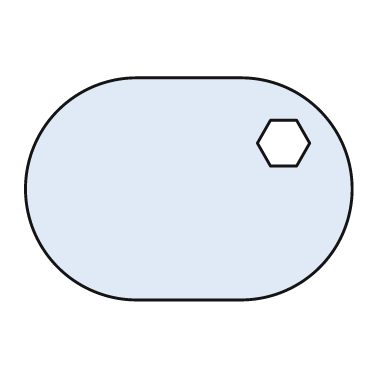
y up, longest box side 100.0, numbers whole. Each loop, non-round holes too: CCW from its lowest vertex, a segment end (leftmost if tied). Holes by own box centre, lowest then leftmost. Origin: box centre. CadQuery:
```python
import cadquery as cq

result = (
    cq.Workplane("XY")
    .moveTo(-16.0, -34.0)
    .lineTo(16.0, -34.0)
    .threePointArc((50.0, 0.0), (16.0, 34.0))
    .lineTo(-16.0, 34.0)
    .threePointArc((-50.0, 0.0), (-16.0, -34.0))
    .close()
    .moveTo(25.0, 7.0)
    .lineTo(33.0, 7.0)
    .lineTo(37.0, 14.0)
    .lineTo(33.0, 21.0)
    .lineTo(25.0, 21.0)
    .lineTo(21.0, 14.0)
    .close()
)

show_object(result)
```